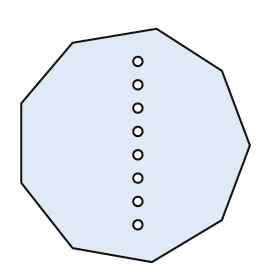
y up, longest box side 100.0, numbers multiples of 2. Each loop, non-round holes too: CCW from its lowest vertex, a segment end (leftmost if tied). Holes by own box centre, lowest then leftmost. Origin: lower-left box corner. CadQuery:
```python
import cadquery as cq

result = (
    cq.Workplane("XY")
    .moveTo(56.0, 0.0)
    .lineTo(86.0, 18.0)
    .lineTo(98.0, 50.0)
    .lineTo(86.0, 82.0)
    .lineTo(58.0, 100.0)
    .lineTo(22.0, 94.0)
    .lineTo(0.0, 68.0)
    .lineTo(0.0, 34.0)
    .lineTo(22.0, 6.0)
    .close()
    .moveTo(50.0, 16.0)
    .circle(2.0)
    .moveTo(50.0, 26.0)
    .circle(2.0)
    .moveTo(50.0, 36.0)
    .circle(2.0)
    .moveTo(50.0, 46.0)
    .circle(2.0)
    .moveTo(50.0, 56.0)
    .circle(2.0)
    .moveTo(50.0, 66.0)
    .circle(2.0)
    .moveTo(50.0, 76.0)
    .circle(2.0)
    .moveTo(50.0, 86.0)
    .circle(2.0)
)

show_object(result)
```